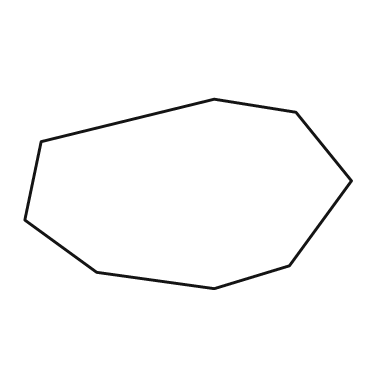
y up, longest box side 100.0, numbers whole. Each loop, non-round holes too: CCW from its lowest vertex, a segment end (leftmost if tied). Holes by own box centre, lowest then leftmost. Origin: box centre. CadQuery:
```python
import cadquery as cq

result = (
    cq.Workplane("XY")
    .moveTo(8.0, -29.0)
    .lineTo(31.0, -22.0)
    .lineTo(50.0, 4.0)
    .lineTo(33.0, 25.0)
    .lineTo(8.0, 29.0)
    .lineTo(-45.0, 16.0)
    .lineTo(-50.0, -8.0)
    .lineTo(-28.0, -24.0)
    .close()
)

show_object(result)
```